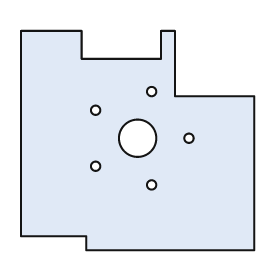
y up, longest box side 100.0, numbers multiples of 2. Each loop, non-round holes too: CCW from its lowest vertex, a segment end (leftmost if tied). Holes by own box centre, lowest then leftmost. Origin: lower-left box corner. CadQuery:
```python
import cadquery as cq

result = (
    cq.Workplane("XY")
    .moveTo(28.0, 0.0)
    .lineTo(100.0, 0.0)
    .lineTo(100.0, 66.0)
    .lineTo(66.0, 66.0)
    .lineTo(66.0, 94.0)
    .lineTo(60.0, 94.0)
    .lineTo(60.0, 82.0)
    .lineTo(26.0, 82.0)
    .lineTo(26.0, 94.0)
    .lineTo(0.0, 94.0)
    .lineTo(0.0, 6.0)
    .lineTo(28.0, 6.0)
    .close()
    .moveTo(56.0, 28.0)
    .circle(2.0)
    .moveTo(32.0, 36.0)
    .circle(2.0)
    .moveTo(50.0, 48.0)
    .circle(8.0)
    .moveTo(72.0, 48.0)
    .circle(2.0)
    .moveTo(32.0, 60.0)
    .circle(2.0)
    .moveTo(56.0, 68.0)
    .circle(2.0)
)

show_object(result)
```